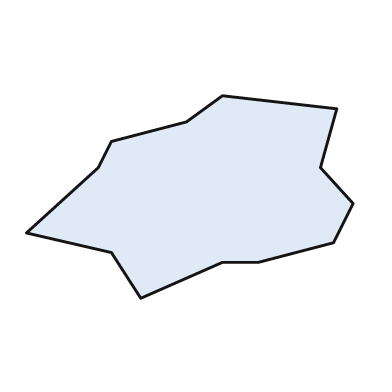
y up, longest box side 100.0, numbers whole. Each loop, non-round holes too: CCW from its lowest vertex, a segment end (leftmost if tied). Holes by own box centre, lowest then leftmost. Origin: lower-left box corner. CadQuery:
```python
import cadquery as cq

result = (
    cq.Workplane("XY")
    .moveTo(35.0, 0.0)
    .lineTo(60.0, 11.0)
    .lineTo(71.0, 11.0)
    .lineTo(94.0, 17.0)
    .lineTo(100.0, 29.0)
    .lineTo(90.0, 40.0)
    .lineTo(95.0, 58.0)
    .lineTo(60.0, 62.0)
    .lineTo(49.0, 54.0)
    .lineTo(26.0, 48.0)
    .lineTo(22.0, 40.0)
    .lineTo(0.0, 20.0)
    .lineTo(26.0, 14.0)
    .close()
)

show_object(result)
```